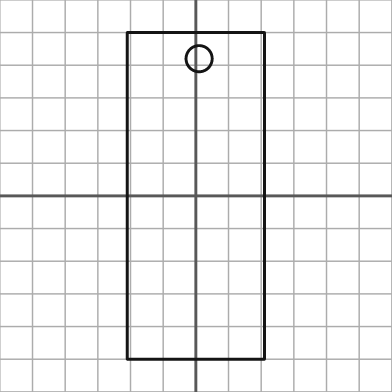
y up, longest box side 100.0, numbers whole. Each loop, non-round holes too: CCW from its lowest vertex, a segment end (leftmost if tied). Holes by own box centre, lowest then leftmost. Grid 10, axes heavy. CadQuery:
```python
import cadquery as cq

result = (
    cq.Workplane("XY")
    .moveTo(-21.0, -50.0)
    .lineTo(21.0, -50.0)
    .lineTo(21.0, 50.0)
    .lineTo(-21.0, 50.0)
    .close()
    .moveTo(1.0, 42.0)
    .circle(4.0)
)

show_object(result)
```